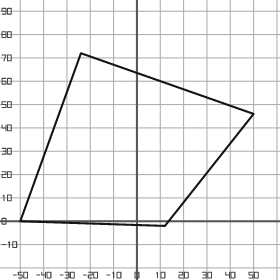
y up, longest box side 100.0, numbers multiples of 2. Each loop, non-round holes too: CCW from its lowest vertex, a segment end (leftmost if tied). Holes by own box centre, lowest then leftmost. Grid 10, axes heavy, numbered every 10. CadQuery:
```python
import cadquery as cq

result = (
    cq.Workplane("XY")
    .moveTo(12.0, -2.0)
    .lineTo(50.0, 46.0)
    .lineTo(-24.0, 72.0)
    .lineTo(-50.0, 0.0)
    .close()
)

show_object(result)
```